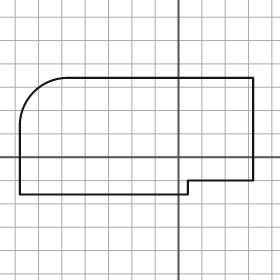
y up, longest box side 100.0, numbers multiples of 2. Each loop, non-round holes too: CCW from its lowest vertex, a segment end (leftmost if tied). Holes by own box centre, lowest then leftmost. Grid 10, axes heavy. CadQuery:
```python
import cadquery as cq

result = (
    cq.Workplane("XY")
    .moveTo(-68.0, -16.0)
    .lineTo(4.0, -16.0)
    .lineTo(4.0, -10.0)
    .lineTo(32.0, -10.0)
    .lineTo(32.0, 34.0)
    .lineTo(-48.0, 34.0)
    .threePointArc((-62.0, 28.0), (-68.0, 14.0))
    .close()
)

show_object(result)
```